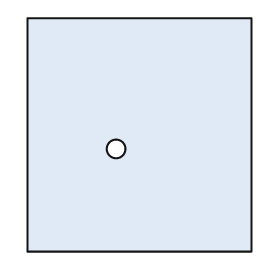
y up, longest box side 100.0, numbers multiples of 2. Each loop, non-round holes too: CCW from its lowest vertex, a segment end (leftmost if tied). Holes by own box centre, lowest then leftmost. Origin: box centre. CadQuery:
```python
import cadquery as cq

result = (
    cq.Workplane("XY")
    .moveTo(-48.0, -50.0)
    .lineTo(48.0, -50.0)
    .lineTo(48.0, 50.0)
    .lineTo(-48.0, 50.0)
    .close()
    .moveTo(-10.0, -6.0)
    .circle(4.0)
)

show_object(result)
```